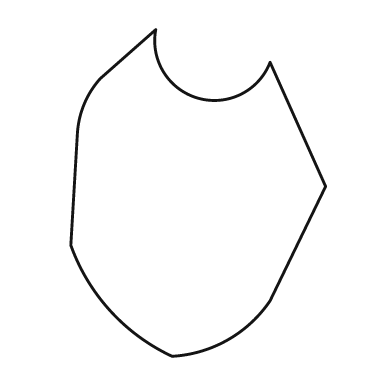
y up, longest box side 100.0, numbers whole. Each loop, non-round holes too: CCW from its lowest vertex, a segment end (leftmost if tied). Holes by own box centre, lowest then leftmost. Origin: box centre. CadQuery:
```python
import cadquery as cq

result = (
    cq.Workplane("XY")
    .moveTo(-8.0, -50.0)
    .threePointArc((9.0, -45.0), (22.0, -33.0))
    .lineTo(39.0, 2.0)
    .lineTo(22.0, 40.0)
    .threePointArc((0.0, 29.0), (-13.0, 50.0))
    .lineTo(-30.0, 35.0)
    .threePointArc((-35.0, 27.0), (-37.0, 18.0))
    .lineTo(-39.0, -16.0)
    .threePointArc((-27.0, -36.0), (-8.0, -50.0))
    .close()
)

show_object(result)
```